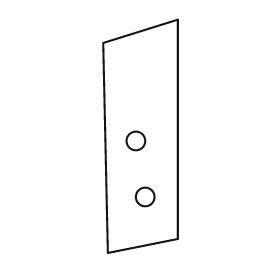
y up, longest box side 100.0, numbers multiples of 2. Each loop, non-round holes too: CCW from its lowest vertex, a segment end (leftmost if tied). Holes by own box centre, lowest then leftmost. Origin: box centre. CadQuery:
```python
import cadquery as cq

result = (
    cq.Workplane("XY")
    .moveTo(-14.0, -50.0)
    .lineTo(16.0, -44.0)
    .lineTo(16.0, 50.0)
    .lineTo(-16.0, 40.0)
    .close()
    .moveTo(2.0, -26.0)
    .circle(4.0)
    .moveTo(-2.0, -2.0)
    .circle(4.0)
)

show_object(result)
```